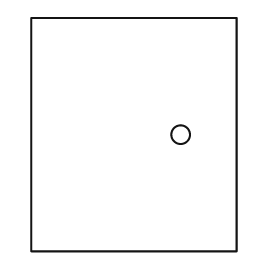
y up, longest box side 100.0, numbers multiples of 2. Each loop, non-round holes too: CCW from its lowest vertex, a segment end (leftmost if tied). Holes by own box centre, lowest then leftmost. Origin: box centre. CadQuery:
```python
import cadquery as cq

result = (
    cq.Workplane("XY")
    .moveTo(-44.0, -50.0)
    .lineTo(44.0, -50.0)
    .lineTo(44.0, 50.0)
    .lineTo(-44.0, 50.0)
    .close()
    .moveTo(20.0, 0.0)
    .circle(4.0)
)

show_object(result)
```